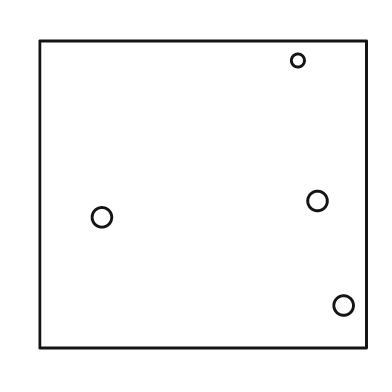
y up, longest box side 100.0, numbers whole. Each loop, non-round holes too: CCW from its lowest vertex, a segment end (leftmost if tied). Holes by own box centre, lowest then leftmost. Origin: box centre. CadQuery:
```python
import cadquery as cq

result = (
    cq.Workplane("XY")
    .moveTo(-50.0, -47.0)
    .lineTo(50.0, -47.0)
    .lineTo(50.0, 47.0)
    .lineTo(-50.0, 47.0)
    .close()
    .moveTo(43.0, -34.0)
    .circle(3.0)
    .moveTo(-31.0, -7.0)
    .circle(3.0)
    .moveTo(35.0, -2.0)
    .circle(3.0)
    .moveTo(29.0, 41.0)
    .circle(2.0)
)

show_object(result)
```